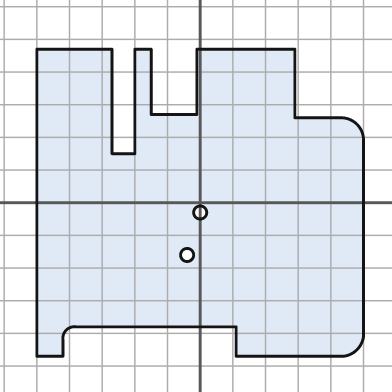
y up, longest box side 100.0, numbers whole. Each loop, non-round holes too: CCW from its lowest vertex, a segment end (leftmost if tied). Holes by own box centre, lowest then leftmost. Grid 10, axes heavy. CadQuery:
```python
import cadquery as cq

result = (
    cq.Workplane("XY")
    .moveTo(-50.0, -47.0)
    .lineTo(-42.0, -47.0)
    .lineTo(-42.0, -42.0)
    .threePointArc((-41.0, -39.0), (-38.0, -38.0))
    .lineTo(11.0, -38.0)
    .lineTo(11.0, -47.0)
    .lineTo(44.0, -47.0)
    .threePointArc((48.0, -45.0), (50.0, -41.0))
    .lineTo(50.0, 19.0)
    .threePointArc((48.0, 24.0), (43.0, 26.0))
    .lineTo(29.0, 26.0)
    .lineTo(29.0, 47.0)
    .lineTo(-1.0, 47.0)
    .lineTo(-1.0, 27.0)
    .lineTo(-15.0, 27.0)
    .lineTo(-15.0, 47.0)
    .lineTo(-20.0, 47.0)
    .lineTo(-20.0, 15.0)
    .lineTo(-27.0, 15.0)
    .lineTo(-27.0, 47.0)
    .lineTo(-50.0, 47.0)
    .close()
    .moveTo(-4.0, -16.0)
    .circle(2.0)
    .moveTo(0.0, -3.0)
    .circle(2.0)
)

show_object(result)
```